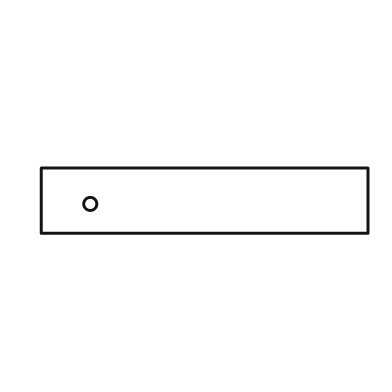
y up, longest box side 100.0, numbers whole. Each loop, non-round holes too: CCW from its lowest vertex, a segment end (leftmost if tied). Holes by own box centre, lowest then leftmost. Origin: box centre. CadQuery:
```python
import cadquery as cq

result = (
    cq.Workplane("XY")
    .moveTo(-50.0, -10.0)
    .lineTo(50.0, -10.0)
    .lineTo(50.0, 10.0)
    .lineTo(-50.0, 10.0)
    .close()
    .moveTo(-35.0, -1.0)
    .circle(2.0)
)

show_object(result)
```